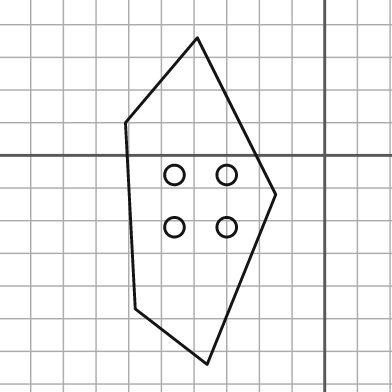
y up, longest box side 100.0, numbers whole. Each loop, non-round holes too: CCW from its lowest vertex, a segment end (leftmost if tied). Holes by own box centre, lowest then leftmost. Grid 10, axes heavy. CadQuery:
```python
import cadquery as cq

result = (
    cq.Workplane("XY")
    .moveTo(-36.0, -64.0)
    .lineTo(-15.0, -12.0)
    .lineTo(-39.0, 36.0)
    .lineTo(-61.0, 10.0)
    .lineTo(-58.0, -47.0)
    .close()
    .moveTo(-46.0, -22.0)
    .circle(3.0)
    .moveTo(-30.0, -22.0)
    .circle(3.0)
    .moveTo(-46.0, -6.0)
    .circle(3.0)
    .moveTo(-30.0, -6.0)
    .circle(3.0)
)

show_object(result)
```